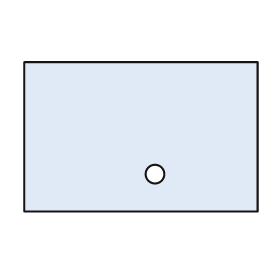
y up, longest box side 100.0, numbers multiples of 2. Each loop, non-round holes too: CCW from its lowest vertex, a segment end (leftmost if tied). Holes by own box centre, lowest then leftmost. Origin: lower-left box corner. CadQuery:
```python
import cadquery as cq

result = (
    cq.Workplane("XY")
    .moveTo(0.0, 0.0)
    .lineTo(100.0, 0.0)
    .lineTo(100.0, 64.0)
    .lineTo(0.0, 64.0)
    .close()
    .moveTo(56.0, 16.0)
    .circle(4.0)
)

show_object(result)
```